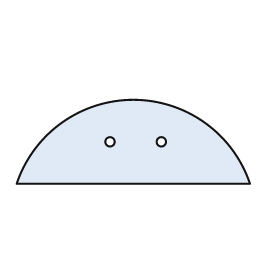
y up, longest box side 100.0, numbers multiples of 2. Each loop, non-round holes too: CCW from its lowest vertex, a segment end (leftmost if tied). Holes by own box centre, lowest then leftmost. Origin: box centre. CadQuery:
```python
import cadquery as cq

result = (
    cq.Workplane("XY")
    .moveTo(-50.0, -18.0)
    .lineTo(50.0, -18.0)
    .threePointArc((0.0, 18.0), (-50.0, -18.0))
    .close()
    .moveTo(-10.0, 0.0)
    .circle(2.0)
    .moveTo(12.0, 0.0)
    .circle(2.0)
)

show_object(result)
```